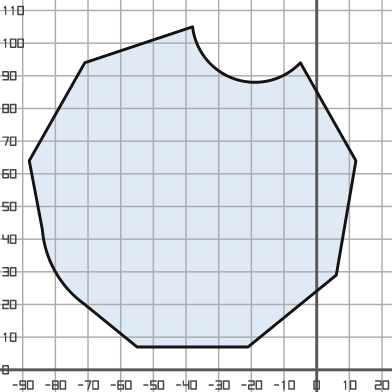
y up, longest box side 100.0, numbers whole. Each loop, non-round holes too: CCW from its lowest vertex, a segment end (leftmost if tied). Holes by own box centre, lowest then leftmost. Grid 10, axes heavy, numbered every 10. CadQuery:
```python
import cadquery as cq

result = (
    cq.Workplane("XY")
    .moveTo(-55.0, 7.0)
    .lineTo(-21.0, 7.0)
    .lineTo(6.0, 29.0)
    .lineTo(12.0, 64.0)
    .lineTo(-5.0, 94.0)
    .threePointArc((-25.0, 89.0), (-38.0, 105.0))
    .lineTo(-71.0, 94.0)
    .lineTo(-88.0, 64.0)
    .lineTo(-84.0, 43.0)
    .threePointArc((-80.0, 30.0), (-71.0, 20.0))
    .close()
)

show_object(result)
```